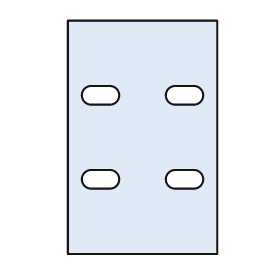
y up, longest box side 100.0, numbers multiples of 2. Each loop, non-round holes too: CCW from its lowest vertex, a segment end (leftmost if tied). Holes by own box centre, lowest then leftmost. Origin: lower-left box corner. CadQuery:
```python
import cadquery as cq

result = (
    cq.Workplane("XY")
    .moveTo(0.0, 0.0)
    .lineTo(64.0, 0.0)
    .lineTo(64.0, 100.0)
    .lineTo(0.0, 100.0)
    .close()
    .moveTo(10.0, 28.0)
    .lineTo(18.0, 28.0)
    .threePointArc((22.0, 32.0), (18.0, 36.0))
    .lineTo(10.0, 36.0)
    .threePointArc((6.0, 32.0), (10.0, 28.0))
    .close()
    .moveTo(46.0, 28.0)
    .lineTo(54.0, 28.0)
    .threePointArc((58.0, 32.0), (54.0, 36.0))
    .lineTo(46.0, 36.0)
    .threePointArc((42.0, 32.0), (46.0, 28.0))
    .close()
    .moveTo(10.0, 64.0)
    .lineTo(18.0, 64.0)
    .threePointArc((22.0, 68.0), (18.0, 72.0))
    .lineTo(10.0, 72.0)
    .threePointArc((6.0, 68.0), (10.0, 64.0))
    .close()
    .moveTo(46.0, 64.0)
    .lineTo(54.0, 64.0)
    .threePointArc((58.0, 68.0), (54.0, 72.0))
    .lineTo(46.0, 72.0)
    .threePointArc((42.0, 68.0), (46.0, 64.0))
    .close()
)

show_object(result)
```